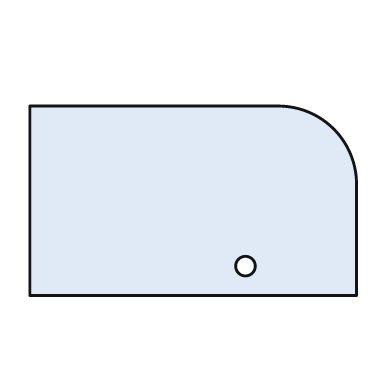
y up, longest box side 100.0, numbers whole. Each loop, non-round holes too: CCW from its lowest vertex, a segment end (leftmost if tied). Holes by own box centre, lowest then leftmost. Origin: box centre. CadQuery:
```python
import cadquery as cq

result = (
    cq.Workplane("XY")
    .moveTo(-50.0, -29.0)
    .lineTo(50.0, -29.0)
    .lineTo(50.0, 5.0)
    .threePointArc((43.0, 22.0), (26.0, 29.0))
    .lineTo(-50.0, 29.0)
    .close()
    .moveTo(16.0, -20.0)
    .circle(3.0)
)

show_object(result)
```